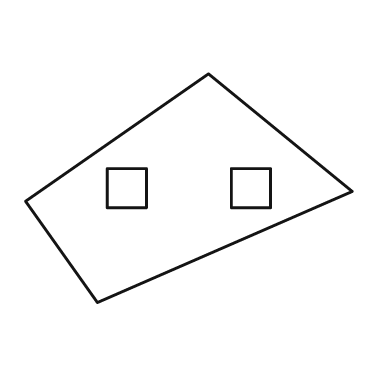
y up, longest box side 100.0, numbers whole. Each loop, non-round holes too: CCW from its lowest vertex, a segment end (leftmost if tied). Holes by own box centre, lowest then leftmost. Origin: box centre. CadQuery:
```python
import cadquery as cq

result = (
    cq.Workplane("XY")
    .moveTo(-28.0, -35.0)
    .lineTo(50.0, -1.0)
    .lineTo(6.0, 35.0)
    .lineTo(-50.0, -4.0)
    .close()
    .moveTo(-25.0, -6.0)
    .lineTo(-13.0, -6.0)
    .lineTo(-13.0, 6.0)
    .lineTo(-25.0, 6.0)
    .close()
    .moveTo(13.0, -6.0)
    .lineTo(25.0, -6.0)
    .lineTo(25.0, 6.0)
    .lineTo(13.0, 6.0)
    .close()
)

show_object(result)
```